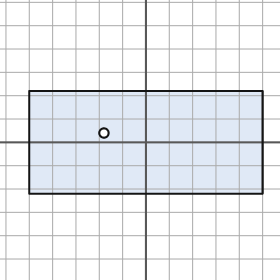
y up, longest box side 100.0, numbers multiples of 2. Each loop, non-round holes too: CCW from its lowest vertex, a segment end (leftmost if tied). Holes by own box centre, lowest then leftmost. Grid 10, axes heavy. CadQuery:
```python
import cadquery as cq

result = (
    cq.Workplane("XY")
    .moveTo(-50.0, -22.0)
    .lineTo(50.0, -22.0)
    .lineTo(50.0, 22.0)
    .lineTo(-50.0, 22.0)
    .close()
    .moveTo(-18.0, 4.0)
    .circle(2.0)
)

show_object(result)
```